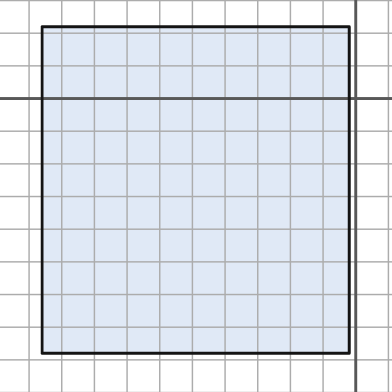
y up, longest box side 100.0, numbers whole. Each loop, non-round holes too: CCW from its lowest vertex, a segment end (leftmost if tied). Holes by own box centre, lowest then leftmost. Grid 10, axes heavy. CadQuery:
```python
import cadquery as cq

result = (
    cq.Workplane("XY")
    .moveTo(-96.0, -78.0)
    .lineTo(-2.0, -78.0)
    .lineTo(-2.0, 22.0)
    .lineTo(-96.0, 22.0)
    .close()
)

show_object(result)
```